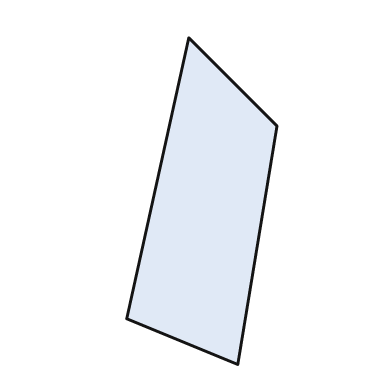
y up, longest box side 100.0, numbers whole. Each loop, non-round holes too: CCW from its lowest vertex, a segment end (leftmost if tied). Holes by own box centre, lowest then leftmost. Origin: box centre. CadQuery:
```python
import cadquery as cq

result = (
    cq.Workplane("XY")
    .moveTo(11.0, -50.0)
    .lineTo(23.0, 23.0)
    .lineTo(-4.0, 50.0)
    .lineTo(-23.0, -36.0)
    .close()
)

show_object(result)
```